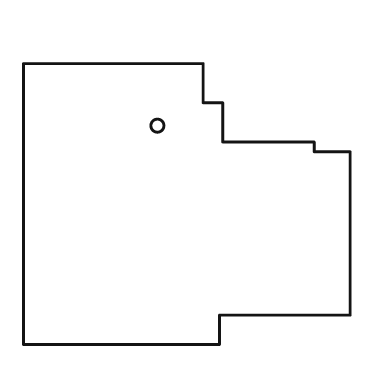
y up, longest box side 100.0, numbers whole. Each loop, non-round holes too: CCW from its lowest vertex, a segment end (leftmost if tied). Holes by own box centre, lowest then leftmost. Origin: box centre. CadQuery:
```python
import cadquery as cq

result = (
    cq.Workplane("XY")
    .moveTo(-50.0, -43.0)
    .lineTo(10.0, -43.0)
    .lineTo(10.0, -34.0)
    .lineTo(50.0, -34.0)
    .lineTo(50.0, 16.0)
    .lineTo(39.0, 16.0)
    .lineTo(39.0, 19.0)
    .lineTo(11.0, 19.0)
    .lineTo(11.0, 31.0)
    .lineTo(5.0, 31.0)
    .lineTo(5.0, 43.0)
    .lineTo(-50.0, 43.0)
    .close()
    .moveTo(-9.0, 24.0)
    .circle(2.0)
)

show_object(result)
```